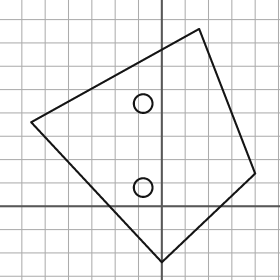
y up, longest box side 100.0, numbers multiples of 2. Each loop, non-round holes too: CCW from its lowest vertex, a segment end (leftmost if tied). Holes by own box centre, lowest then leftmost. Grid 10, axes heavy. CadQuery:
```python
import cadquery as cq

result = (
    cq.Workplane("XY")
    .moveTo(0.0, -24.0)
    .lineTo(40.0, 14.0)
    .lineTo(16.0, 76.0)
    .lineTo(-56.0, 36.0)
    .close()
    .moveTo(-8.0, 8.0)
    .circle(4.0)
    .moveTo(-8.0, 44.0)
    .circle(4.0)
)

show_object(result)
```